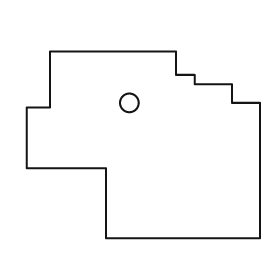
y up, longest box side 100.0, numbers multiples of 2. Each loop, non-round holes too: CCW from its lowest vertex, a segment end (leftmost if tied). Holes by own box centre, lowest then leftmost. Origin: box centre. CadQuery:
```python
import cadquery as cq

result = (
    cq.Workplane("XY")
    .moveTo(-16.0, -40.0)
    .lineTo(50.0, -40.0)
    .lineTo(50.0, 18.0)
    .lineTo(38.0, 18.0)
    .lineTo(38.0, 26.0)
    .lineTo(22.0, 26.0)
    .lineTo(22.0, 30.0)
    .lineTo(14.0, 30.0)
    .lineTo(14.0, 40.0)
    .lineTo(-40.0, 40.0)
    .lineTo(-40.0, 16.0)
    .lineTo(-50.0, 16.0)
    .lineTo(-50.0, -10.0)
    .lineTo(-16.0, -10.0)
    .close()
    .moveTo(-6.0, 18.0)
    .circle(4.0)
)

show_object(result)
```